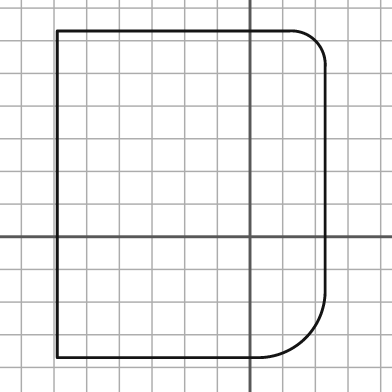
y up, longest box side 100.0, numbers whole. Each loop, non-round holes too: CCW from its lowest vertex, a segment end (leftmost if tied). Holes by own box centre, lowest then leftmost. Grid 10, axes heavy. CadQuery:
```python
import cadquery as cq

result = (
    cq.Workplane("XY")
    .moveTo(-59.0, -37.0)
    .lineTo(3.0, -37.0)
    .threePointArc((17.0, -31.0), (23.0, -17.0))
    .lineTo(23.0, 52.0)
    .threePointArc((20.0, 60.0), (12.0, 63.0))
    .lineTo(-59.0, 63.0)
    .close()
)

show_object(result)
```